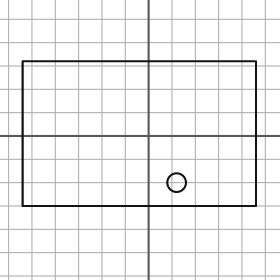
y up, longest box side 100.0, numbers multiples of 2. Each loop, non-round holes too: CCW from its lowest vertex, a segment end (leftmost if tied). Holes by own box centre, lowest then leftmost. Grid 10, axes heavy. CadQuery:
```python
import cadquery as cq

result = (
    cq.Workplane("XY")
    .moveTo(-54.0, -30.0)
    .lineTo(46.0, -30.0)
    .lineTo(46.0, 32.0)
    .lineTo(-54.0, 32.0)
    .close()
    .moveTo(12.0, -20.0)
    .circle(4.0)
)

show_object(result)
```